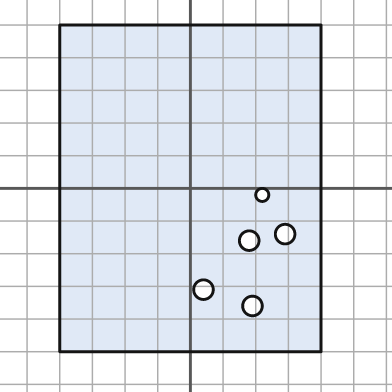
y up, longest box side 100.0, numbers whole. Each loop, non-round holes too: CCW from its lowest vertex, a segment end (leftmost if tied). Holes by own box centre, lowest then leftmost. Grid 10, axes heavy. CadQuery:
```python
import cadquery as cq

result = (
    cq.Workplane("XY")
    .moveTo(-40.0, -50.0)
    .lineTo(40.0, -50.0)
    .lineTo(40.0, 50.0)
    .lineTo(-40.0, 50.0)
    .close()
    .moveTo(19.0, -36.0)
    .circle(3.0)
    .moveTo(4.0, -31.0)
    .circle(3.0)
    .moveTo(18.0, -16.0)
    .circle(3.0)
    .moveTo(29.0, -14.0)
    .circle(3.0)
    .moveTo(22.0, -2.0)
    .circle(2.0)
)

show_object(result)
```